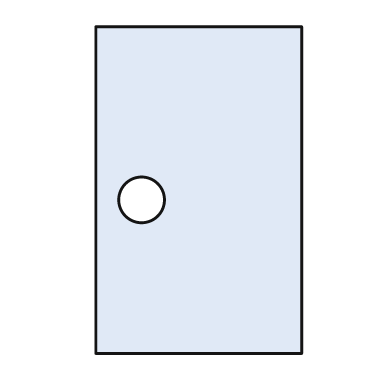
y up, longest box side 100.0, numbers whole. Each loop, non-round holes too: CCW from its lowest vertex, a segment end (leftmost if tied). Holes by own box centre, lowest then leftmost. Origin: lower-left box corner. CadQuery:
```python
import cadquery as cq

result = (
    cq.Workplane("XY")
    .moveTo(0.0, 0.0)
    .lineTo(63.0, 0.0)
    .lineTo(63.0, 100.0)
    .lineTo(0.0, 100.0)
    .close()
    .moveTo(14.0, 47.0)
    .circle(7.0)
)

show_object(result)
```